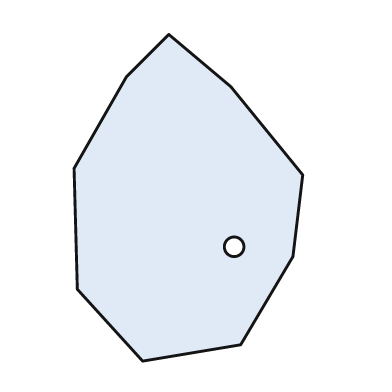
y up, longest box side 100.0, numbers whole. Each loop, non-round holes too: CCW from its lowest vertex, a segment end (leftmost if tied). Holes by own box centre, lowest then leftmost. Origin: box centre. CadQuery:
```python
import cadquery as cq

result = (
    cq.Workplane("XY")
    .moveTo(-14.0, -50.0)
    .lineTo(16.0, -45.0)
    .lineTo(32.0, -18.0)
    .lineTo(35.0, 7.0)
    .lineTo(13.0, 34.0)
    .lineTo(-6.0, 50.0)
    .lineTo(-19.0, 37.0)
    .lineTo(-35.0, 9.0)
    .lineTo(-34.0, -28.0)
    .close()
    .moveTo(14.0, -15.0)
    .circle(3.0)
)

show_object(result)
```